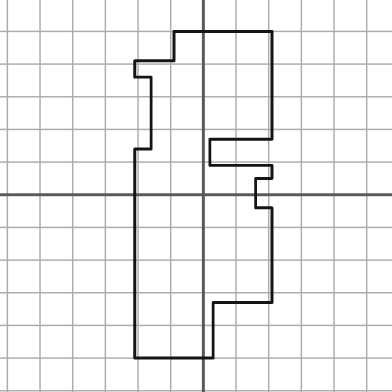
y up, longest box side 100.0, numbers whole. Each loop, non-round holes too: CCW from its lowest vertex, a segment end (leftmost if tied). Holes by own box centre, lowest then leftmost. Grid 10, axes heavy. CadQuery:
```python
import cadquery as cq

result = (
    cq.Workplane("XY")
    .moveTo(-21.0, -50.0)
    .lineTo(3.0, -50.0)
    .lineTo(3.0, -33.0)
    .lineTo(21.0, -33.0)
    .lineTo(21.0, -4.0)
    .lineTo(16.0, -4.0)
    .lineTo(16.0, 5.0)
    .lineTo(21.0, 5.0)
    .lineTo(21.0, 9.0)
    .lineTo(2.0, 9.0)
    .lineTo(2.0, 17.0)
    .lineTo(21.0, 17.0)
    .lineTo(21.0, 50.0)
    .lineTo(-9.0, 50.0)
    .lineTo(-9.0, 41.0)
    .lineTo(-21.0, 41.0)
    .lineTo(-21.0, 36.0)
    .lineTo(-16.0, 36.0)
    .lineTo(-16.0, 14.0)
    .lineTo(-21.0, 14.0)
    .close()
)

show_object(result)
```